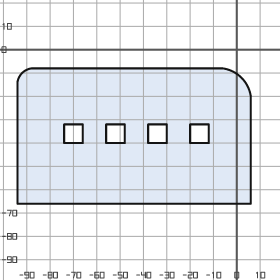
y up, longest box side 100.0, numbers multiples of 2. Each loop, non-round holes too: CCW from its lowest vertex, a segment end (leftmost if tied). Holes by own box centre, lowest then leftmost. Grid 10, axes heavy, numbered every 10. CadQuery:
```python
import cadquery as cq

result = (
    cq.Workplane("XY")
    .moveTo(-94.0, -66.0)
    .lineTo(6.0, -66.0)
    .lineTo(6.0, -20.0)
    .threePointArc((2.0, -12.0), (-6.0, -8.0))
    .lineTo(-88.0, -8.0)
    .threePointArc((-92.0, -10.0), (-94.0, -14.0))
    .close()
    .moveTo(-74.0, -40.0)
    .lineTo(-66.0, -40.0)
    .lineTo(-66.0, -32.0)
    .lineTo(-74.0, -32.0)
    .close()
    .moveTo(-56.0, -40.0)
    .lineTo(-48.0, -40.0)
    .lineTo(-48.0, -32.0)
    .lineTo(-56.0, -32.0)
    .close()
    .moveTo(-38.0, -40.0)
    .lineTo(-30.0, -40.0)
    .lineTo(-30.0, -32.0)
    .lineTo(-38.0, -32.0)
    .close()
    .moveTo(-20.0, -40.0)
    .lineTo(-12.0, -40.0)
    .lineTo(-12.0, -32.0)
    .lineTo(-20.0, -32.0)
    .close()
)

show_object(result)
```